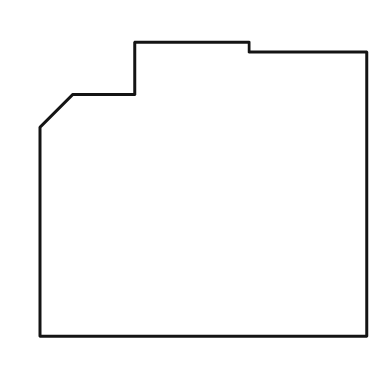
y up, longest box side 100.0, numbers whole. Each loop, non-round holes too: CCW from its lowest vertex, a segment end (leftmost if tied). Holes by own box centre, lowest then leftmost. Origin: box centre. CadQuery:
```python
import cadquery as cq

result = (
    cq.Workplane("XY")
    .moveTo(-50.0, -45.0)
    .lineTo(50.0, -45.0)
    .lineTo(50.0, 42.0)
    .lineTo(14.0, 42.0)
    .lineTo(14.0, 45.0)
    .lineTo(-21.0, 45.0)
    .lineTo(-21.0, 29.0)
    .lineTo(-40.0, 29.0)
    .lineTo(-50.0, 19.0)
    .close()
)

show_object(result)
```